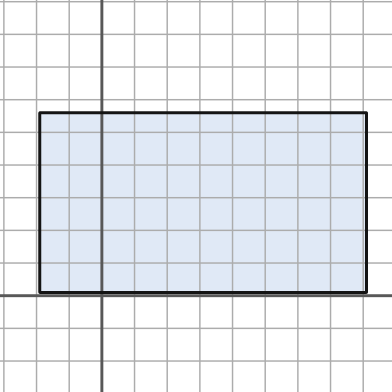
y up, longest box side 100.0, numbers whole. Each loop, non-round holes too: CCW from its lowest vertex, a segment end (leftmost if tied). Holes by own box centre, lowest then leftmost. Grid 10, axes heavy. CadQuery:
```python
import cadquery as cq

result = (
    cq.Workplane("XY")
    .moveTo(-19.0, 1.0)
    .lineTo(81.0, 1.0)
    .lineTo(81.0, 56.0)
    .lineTo(-19.0, 56.0)
    .close()
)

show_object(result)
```